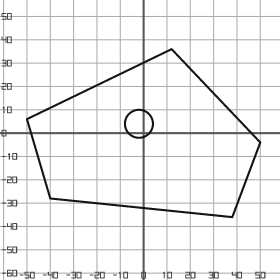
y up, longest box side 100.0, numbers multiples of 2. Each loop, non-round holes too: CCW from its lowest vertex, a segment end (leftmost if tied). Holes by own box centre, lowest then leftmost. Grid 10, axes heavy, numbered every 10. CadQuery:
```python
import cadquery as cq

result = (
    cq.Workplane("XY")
    .moveTo(38.0, -36.0)
    .lineTo(50.0, -4.0)
    .lineTo(12.0, 36.0)
    .lineTo(-50.0, 6.0)
    .lineTo(-40.0, -28.0)
    .close()
    .moveTo(-2.0, 4.0)
    .circle(6.0)
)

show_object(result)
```